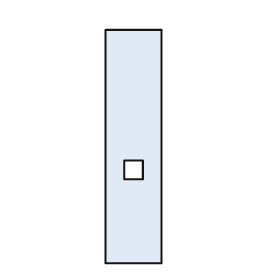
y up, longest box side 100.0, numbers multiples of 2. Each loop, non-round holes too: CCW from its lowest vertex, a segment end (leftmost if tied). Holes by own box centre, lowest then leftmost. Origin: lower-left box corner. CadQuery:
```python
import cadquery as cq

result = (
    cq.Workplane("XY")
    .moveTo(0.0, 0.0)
    .lineTo(24.0, 0.0)
    .lineTo(24.0, 100.0)
    .lineTo(0.0, 100.0)
    .close()
    .moveTo(8.0, 36.0)
    .lineTo(16.0, 36.0)
    .lineTo(16.0, 44.0)
    .lineTo(8.0, 44.0)
    .close()
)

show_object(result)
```